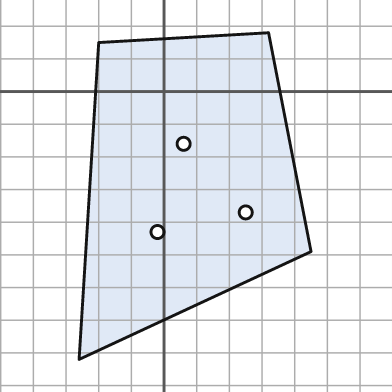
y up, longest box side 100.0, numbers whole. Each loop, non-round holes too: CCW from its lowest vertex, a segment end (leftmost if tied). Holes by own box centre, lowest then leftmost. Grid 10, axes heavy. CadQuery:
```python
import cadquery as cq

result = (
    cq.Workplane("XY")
    .moveTo(-26.0, -82.0)
    .lineTo(45.0, -49.0)
    .lineTo(32.0, 18.0)
    .lineTo(-20.0, 15.0)
    .close()
    .moveTo(-2.0, -43.0)
    .circle(2.0)
    .moveTo(25.0, -37.0)
    .circle(2.0)
    .moveTo(6.0, -16.0)
    .circle(2.0)
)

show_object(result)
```